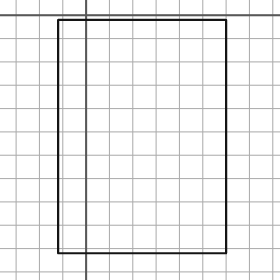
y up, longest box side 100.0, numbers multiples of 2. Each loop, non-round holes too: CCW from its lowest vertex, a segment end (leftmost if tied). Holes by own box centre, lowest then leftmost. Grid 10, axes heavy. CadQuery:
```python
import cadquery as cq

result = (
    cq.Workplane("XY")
    .moveTo(-12.0, -102.0)
    .lineTo(60.0, -102.0)
    .lineTo(60.0, -2.0)
    .lineTo(-12.0, -2.0)
    .close()
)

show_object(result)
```